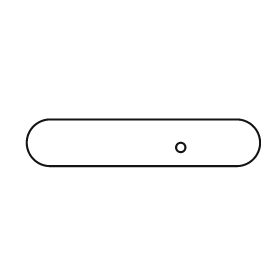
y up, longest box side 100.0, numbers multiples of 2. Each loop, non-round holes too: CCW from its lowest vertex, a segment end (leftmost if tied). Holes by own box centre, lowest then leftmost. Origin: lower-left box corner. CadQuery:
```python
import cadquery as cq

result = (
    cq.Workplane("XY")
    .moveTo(10.0, 0.0)
    .lineTo(90.0, 0.0)
    .threePointArc((100.0, 10.0), (90.0, 20.0))
    .lineTo(10.0, 20.0)
    .threePointArc((0.0, 10.0), (10.0, 0.0))
    .close()
    .moveTo(66.0, 8.0)
    .circle(2.0)
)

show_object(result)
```